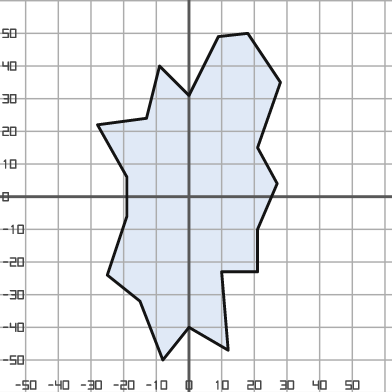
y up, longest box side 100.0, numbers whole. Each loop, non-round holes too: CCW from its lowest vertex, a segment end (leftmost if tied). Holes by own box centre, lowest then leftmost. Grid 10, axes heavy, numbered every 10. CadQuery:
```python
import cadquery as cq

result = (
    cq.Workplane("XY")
    .moveTo(-8.0, -50.0)
    .lineTo(0.0, -40.0)
    .lineTo(12.0, -47.0)
    .lineTo(10.0, -23.0)
    .lineTo(21.0, -23.0)
    .lineTo(21.0, -10.0)
    .lineTo(27.0, 4.0)
    .lineTo(21.0, 15.0)
    .lineTo(28.0, 35.0)
    .lineTo(18.0, 50.0)
    .lineTo(9.0, 49.0)
    .lineTo(0.0, 31.0)
    .lineTo(-9.0, 40.0)
    .lineTo(-13.0, 24.0)
    .lineTo(-28.0, 22.0)
    .lineTo(-19.0, 6.0)
    .lineTo(-19.0, -6.0)
    .lineTo(-25.0, -24.0)
    .lineTo(-15.0, -32.0)
    .close()
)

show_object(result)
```